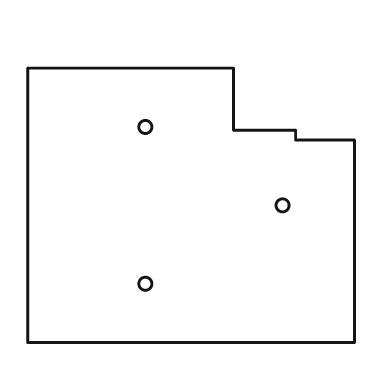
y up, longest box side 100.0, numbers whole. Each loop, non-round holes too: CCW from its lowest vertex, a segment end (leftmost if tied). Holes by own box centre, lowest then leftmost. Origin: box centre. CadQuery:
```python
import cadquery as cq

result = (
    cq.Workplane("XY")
    .moveTo(-50.0, -42.0)
    .lineTo(50.0, -42.0)
    .lineTo(50.0, 20.0)
    .lineTo(32.0, 20.0)
    .lineTo(32.0, 23.0)
    .lineTo(13.0, 23.0)
    .lineTo(13.0, 42.0)
    .lineTo(-50.0, 42.0)
    .close()
    .moveTo(-14.0, -24.0)
    .circle(2.0)
    .moveTo(28.0, 0.0)
    .circle(2.0)
    .moveTo(-14.0, 24.0)
    .circle(2.0)
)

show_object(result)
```